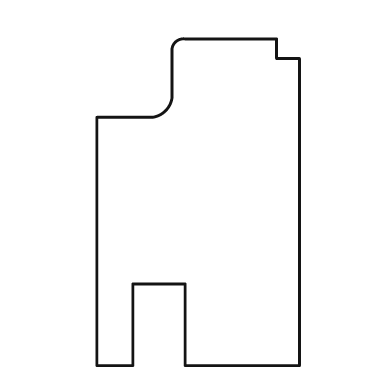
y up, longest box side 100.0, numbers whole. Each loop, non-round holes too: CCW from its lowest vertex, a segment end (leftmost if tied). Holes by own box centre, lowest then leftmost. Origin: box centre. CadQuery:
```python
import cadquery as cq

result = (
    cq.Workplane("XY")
    .moveTo(-31.0, -50.0)
    .lineTo(-20.0, -50.0)
    .lineTo(-20.0, -25.0)
    .lineTo(-4.0, -25.0)
    .lineTo(-4.0, -50.0)
    .lineTo(31.0, -50.0)
    .lineTo(31.0, 44.0)
    .lineTo(24.0, 44.0)
    .lineTo(24.0, 50.0)
    .lineTo(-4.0, 50.0)
    .threePointArc((-7.0, 49.0), (-8.0, 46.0))
    .lineTo(-8.0, 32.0)
    .threePointArc((-10.0, 28.0), (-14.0, 26.0))
    .lineTo(-31.0, 26.0)
    .close()
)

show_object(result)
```